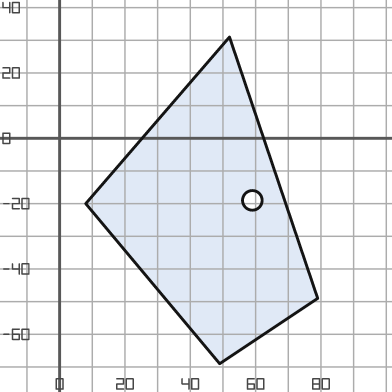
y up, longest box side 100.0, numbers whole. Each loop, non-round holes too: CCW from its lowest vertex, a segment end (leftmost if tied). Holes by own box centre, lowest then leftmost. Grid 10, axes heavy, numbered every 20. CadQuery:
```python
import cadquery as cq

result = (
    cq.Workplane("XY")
    .moveTo(49.0, -69.0)
    .lineTo(79.0, -49.0)
    .lineTo(52.0, 31.0)
    .lineTo(8.0, -20.0)
    .close()
    .moveTo(59.0, -19.0)
    .circle(3.0)
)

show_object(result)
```